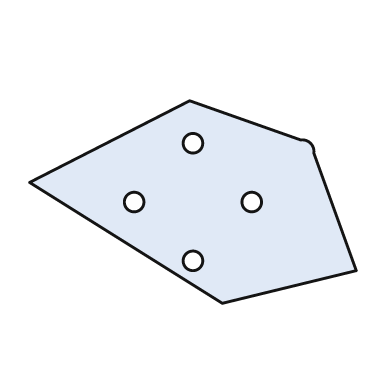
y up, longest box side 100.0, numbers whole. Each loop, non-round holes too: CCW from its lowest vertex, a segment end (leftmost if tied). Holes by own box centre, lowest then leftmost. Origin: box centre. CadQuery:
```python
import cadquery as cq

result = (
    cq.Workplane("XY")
    .moveTo(9.0, -31.0)
    .lineTo(50.0, -21.0)
    .lineTo(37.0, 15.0)
    .threePointArc((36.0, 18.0), (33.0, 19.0))
    .lineTo(-1.0, 31.0)
    .lineTo(-50.0, 6.0)
    .close()
    .moveTo(0.0, -18.0)
    .circle(3.0)
    .moveTo(-18.0, 0.0)
    .circle(3.0)
    .moveTo(18.0, 0.0)
    .circle(3.0)
    .moveTo(0.0, 18.0)
    .circle(3.0)
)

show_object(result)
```